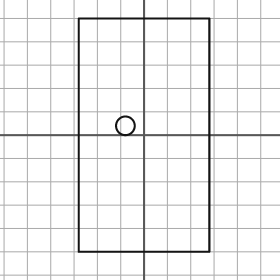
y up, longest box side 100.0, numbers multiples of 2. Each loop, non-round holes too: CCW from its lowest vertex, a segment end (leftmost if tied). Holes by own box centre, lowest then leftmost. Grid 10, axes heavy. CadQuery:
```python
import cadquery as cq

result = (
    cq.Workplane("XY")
    .moveTo(-28.0, -50.0)
    .lineTo(28.0, -50.0)
    .lineTo(28.0, 50.0)
    .lineTo(-28.0, 50.0)
    .close()
    .moveTo(-8.0, 4.0)
    .circle(4.0)
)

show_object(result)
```